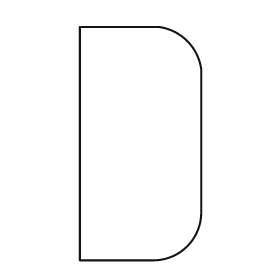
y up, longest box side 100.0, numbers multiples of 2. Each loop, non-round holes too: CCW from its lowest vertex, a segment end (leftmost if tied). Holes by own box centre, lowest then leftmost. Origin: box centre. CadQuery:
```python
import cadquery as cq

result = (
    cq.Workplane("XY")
    .moveTo(-26.0, -50.0)
    .lineTo(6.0, -50.0)
    .threePointArc((20.0, -44.0), (26.0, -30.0))
    .lineTo(26.0, 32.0)
    .threePointArc((20.0, 44.0), (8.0, 50.0))
    .lineTo(-26.0, 50.0)
    .close()
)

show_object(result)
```